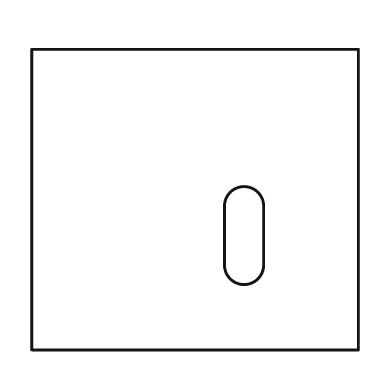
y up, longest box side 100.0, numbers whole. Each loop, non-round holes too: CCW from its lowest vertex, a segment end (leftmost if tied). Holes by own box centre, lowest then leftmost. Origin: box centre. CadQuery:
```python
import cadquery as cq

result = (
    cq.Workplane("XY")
    .moveTo(-50.0, -46.0)
    .lineTo(50.0, -46.0)
    .lineTo(50.0, 46.0)
    .lineTo(-50.0, 46.0)
    .close()
    .moveTo(9.0, -20.0)
    .threePointArc((15.0, -26.0), (21.0, -20.0))
    .lineTo(21.0, -2.0)
    .threePointArc((15.0, 4.0), (9.0, -2.0))
    .close()
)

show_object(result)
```